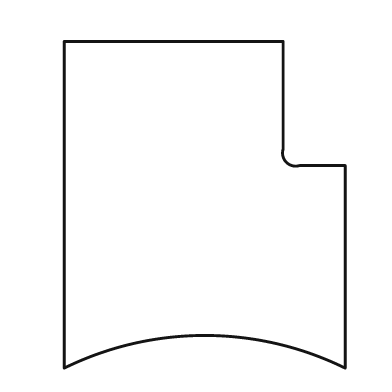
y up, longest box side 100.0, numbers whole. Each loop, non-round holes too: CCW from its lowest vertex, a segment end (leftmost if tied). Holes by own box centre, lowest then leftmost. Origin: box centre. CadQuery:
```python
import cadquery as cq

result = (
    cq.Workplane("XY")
    .moveTo(-43.0, -50.0)
    .threePointArc((0.0, -40.0), (43.0, -50.0))
    .lineTo(43.0, 12.0)
    .lineTo(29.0, 12.0)
    .threePointArc((25.0, 13.0), (24.0, 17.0))
    .lineTo(24.0, 50.0)
    .lineTo(-43.0, 50.0)
    .close()
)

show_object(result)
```